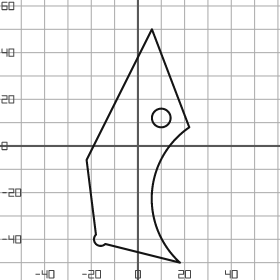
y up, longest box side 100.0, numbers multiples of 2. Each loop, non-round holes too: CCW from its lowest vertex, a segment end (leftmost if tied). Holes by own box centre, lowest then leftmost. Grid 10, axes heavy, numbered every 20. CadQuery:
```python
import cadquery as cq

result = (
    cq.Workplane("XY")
    .moveTo(18.0, -50.0)
    .threePointArc((6.0, -20.0), (22.0, 8.0))
    .lineTo(6.0, 50.0)
    .lineTo(-22.0, -6.0)
    .lineTo(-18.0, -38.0)
    .threePointArc((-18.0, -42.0), (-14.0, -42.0))
    .close()
    .moveTo(10.0, 12.0)
    .circle(4.0)
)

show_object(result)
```